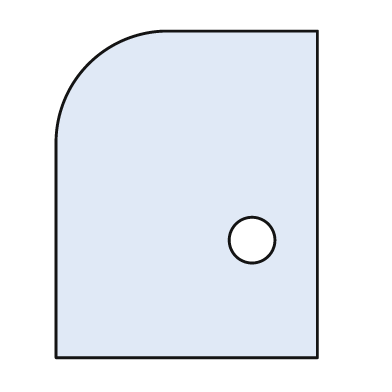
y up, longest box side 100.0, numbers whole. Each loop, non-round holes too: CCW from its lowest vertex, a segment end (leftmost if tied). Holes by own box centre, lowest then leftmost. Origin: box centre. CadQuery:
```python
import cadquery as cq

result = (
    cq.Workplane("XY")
    .moveTo(-40.0, -50.0)
    .lineTo(40.0, -50.0)
    .lineTo(40.0, 50.0)
    .lineTo(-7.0, 50.0)
    .threePointArc((-30.0, 40.0), (-40.0, 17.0))
    .close()
    .moveTo(20.0, -14.0)
    .circle(7.0)
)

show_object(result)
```